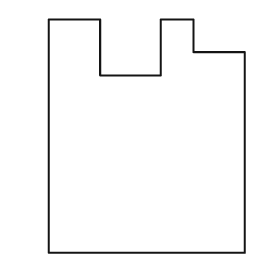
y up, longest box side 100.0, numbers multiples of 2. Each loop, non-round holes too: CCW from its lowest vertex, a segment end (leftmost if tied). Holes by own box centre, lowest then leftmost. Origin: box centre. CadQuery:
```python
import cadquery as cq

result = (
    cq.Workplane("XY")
    .moveTo(-42.0, -50.0)
    .lineTo(42.0, -50.0)
    .lineTo(42.0, 36.0)
    .lineTo(20.0, 36.0)
    .lineTo(20.0, 50.0)
    .lineTo(6.0, 50.0)
    .lineTo(6.0, 26.0)
    .lineTo(-20.0, 26.0)
    .lineTo(-20.0, 50.0)
    .lineTo(-42.0, 50.0)
    .close()
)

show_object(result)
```